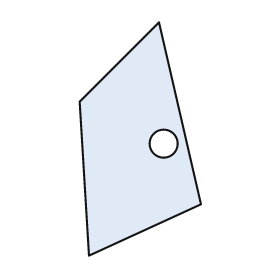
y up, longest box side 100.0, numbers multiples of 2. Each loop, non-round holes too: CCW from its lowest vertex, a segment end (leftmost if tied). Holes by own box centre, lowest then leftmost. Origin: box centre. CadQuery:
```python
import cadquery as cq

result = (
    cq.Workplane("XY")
    .moveTo(-22.0, -50.0)
    .lineTo(26.0, -28.0)
    .lineTo(8.0, 50.0)
    .lineTo(-26.0, 16.0)
    .close()
    .moveTo(10.0, -2.0)
    .circle(6.0)
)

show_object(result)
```